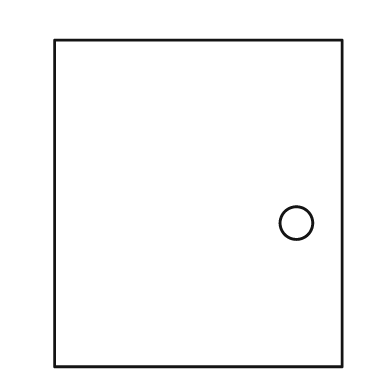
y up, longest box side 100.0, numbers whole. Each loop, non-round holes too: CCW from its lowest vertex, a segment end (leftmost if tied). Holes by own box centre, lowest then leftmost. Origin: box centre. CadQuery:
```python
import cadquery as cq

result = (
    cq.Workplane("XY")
    .moveTo(-44.0, -50.0)
    .lineTo(44.0, -50.0)
    .lineTo(44.0, 50.0)
    .lineTo(-44.0, 50.0)
    .close()
    .moveTo(30.0, -6.0)
    .circle(5.0)
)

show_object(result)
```